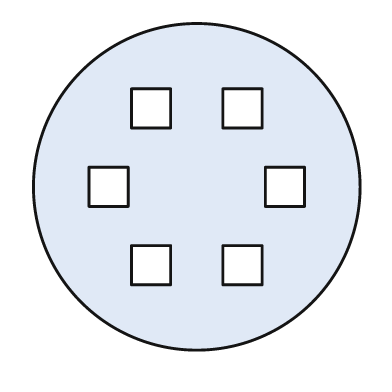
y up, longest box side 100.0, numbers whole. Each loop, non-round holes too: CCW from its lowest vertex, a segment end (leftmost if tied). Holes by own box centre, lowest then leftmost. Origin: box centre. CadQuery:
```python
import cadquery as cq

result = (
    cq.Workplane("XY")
    .moveTo(0.0, 0.0)
    .circle(50.0)
    .moveTo(-20.0, -30.0)
    .lineTo(-8.0, -30.0)
    .lineTo(-8.0, -18.0)
    .lineTo(-20.0, -18.0)
    .close()
    .moveTo(8.0, -30.0)
    .lineTo(20.0, -30.0)
    .lineTo(20.0, -18.0)
    .lineTo(8.0, -18.0)
    .close()
    .moveTo(-33.0, -6.0)
    .lineTo(-21.0, -6.0)
    .lineTo(-21.0, 6.0)
    .lineTo(-33.0, 6.0)
    .close()
    .moveTo(21.0, -6.0)
    .lineTo(33.0, -6.0)
    .lineTo(33.0, 6.0)
    .lineTo(21.0, 6.0)
    .close()
    .moveTo(-20.0, 18.0)
    .lineTo(-8.0, 18.0)
    .lineTo(-8.0, 30.0)
    .lineTo(-20.0, 30.0)
    .close()
    .moveTo(8.0, 18.0)
    .lineTo(20.0, 18.0)
    .lineTo(20.0, 30.0)
    .lineTo(8.0, 30.0)
    .close()
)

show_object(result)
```